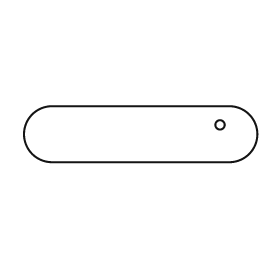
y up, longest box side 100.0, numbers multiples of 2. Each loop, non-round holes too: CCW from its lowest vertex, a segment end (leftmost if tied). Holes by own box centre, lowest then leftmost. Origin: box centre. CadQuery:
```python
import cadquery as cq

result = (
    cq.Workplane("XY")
    .moveTo(-38.0, -12.0)
    .lineTo(38.0, -12.0)
    .threePointArc((50.0, 0.0), (38.0, 12.0))
    .lineTo(-38.0, 12.0)
    .threePointArc((-50.0, 0.0), (-38.0, -12.0))
    .close()
    .moveTo(34.0, 4.0)
    .circle(2.0)
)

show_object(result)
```